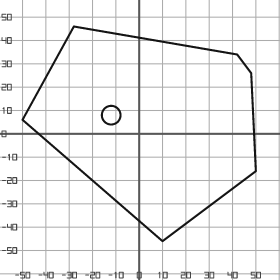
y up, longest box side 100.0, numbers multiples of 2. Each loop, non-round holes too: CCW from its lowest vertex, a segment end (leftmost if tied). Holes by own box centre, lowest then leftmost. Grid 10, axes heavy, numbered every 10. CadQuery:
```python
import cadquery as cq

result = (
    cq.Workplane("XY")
    .moveTo(10.0, -46.0)
    .lineTo(50.0, -16.0)
    .lineTo(48.0, 26.0)
    .lineTo(42.0, 34.0)
    .lineTo(-28.0, 46.0)
    .lineTo(-50.0, 6.0)
    .close()
    .moveTo(-12.0, 8.0)
    .circle(4.0)
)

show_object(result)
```